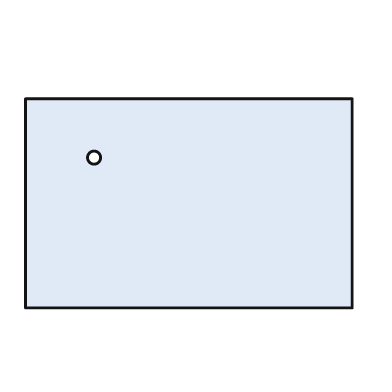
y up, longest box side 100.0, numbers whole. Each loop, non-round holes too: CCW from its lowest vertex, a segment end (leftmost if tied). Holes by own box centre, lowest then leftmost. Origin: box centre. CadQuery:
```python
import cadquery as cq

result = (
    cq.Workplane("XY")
    .moveTo(-50.0, -32.0)
    .lineTo(50.0, -32.0)
    .lineTo(50.0, 32.0)
    .lineTo(-50.0, 32.0)
    .close()
    .moveTo(-29.0, 14.0)
    .circle(2.0)
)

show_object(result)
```